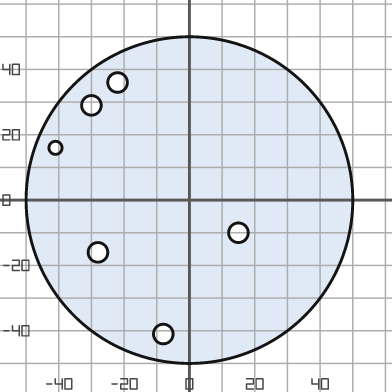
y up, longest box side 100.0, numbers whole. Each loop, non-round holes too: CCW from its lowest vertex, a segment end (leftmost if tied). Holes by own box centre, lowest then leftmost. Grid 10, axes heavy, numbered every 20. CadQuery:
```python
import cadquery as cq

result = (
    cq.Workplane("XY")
    .moveTo(0.0, 0.0)
    .circle(50.0)
    .moveTo(-8.0, -41.0)
    .circle(3.0)
    .moveTo(-28.0, -16.0)
    .circle(3.0)
    .moveTo(15.0, -10.0)
    .circle(3.0)
    .moveTo(-41.0, 16.0)
    .circle(2.0)
    .moveTo(-30.0, 29.0)
    .circle(3.0)
    .moveTo(-22.0, 36.0)
    .circle(3.0)
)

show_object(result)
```